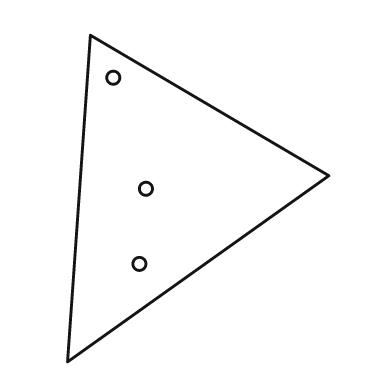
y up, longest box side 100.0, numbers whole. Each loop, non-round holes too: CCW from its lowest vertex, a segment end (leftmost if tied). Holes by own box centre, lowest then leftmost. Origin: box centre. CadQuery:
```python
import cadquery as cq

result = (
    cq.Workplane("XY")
    .moveTo(-40.0, -50.0)
    .lineTo(40.0, 7.0)
    .lineTo(-33.0, 50.0)
    .close()
    .moveTo(-18.0, -20.0)
    .circle(2.0)
    .moveTo(-16.0, 3.0)
    .circle(2.0)
    .moveTo(-26.0, 37.0)
    .circle(2.0)
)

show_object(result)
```